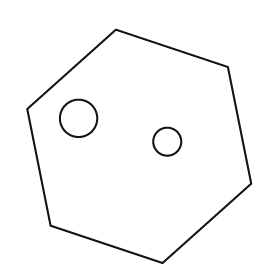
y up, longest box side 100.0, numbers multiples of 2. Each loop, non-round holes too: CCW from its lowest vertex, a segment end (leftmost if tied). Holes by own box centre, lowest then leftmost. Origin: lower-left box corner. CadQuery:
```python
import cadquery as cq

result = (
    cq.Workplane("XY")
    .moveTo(58.0, 0.0)
    .lineTo(96.0, 34.0)
    .lineTo(86.0, 84.0)
    .lineTo(38.0, 100.0)
    .lineTo(0.0, 66.0)
    .lineTo(10.0, 16.0)
    .close()
    .moveTo(60.0, 52.0)
    .circle(6.0)
    .moveTo(22.0, 62.0)
    .circle(8.0)
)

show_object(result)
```